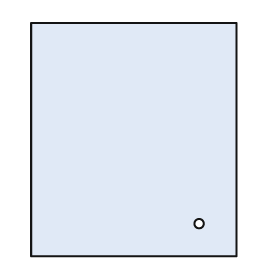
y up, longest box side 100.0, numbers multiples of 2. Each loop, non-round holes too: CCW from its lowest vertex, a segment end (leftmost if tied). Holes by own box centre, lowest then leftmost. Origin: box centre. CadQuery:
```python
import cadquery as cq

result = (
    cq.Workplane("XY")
    .moveTo(-44.0, -50.0)
    .lineTo(44.0, -50.0)
    .lineTo(44.0, 50.0)
    .lineTo(-44.0, 50.0)
    .close()
    .moveTo(28.0, -36.0)
    .circle(2.0)
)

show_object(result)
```